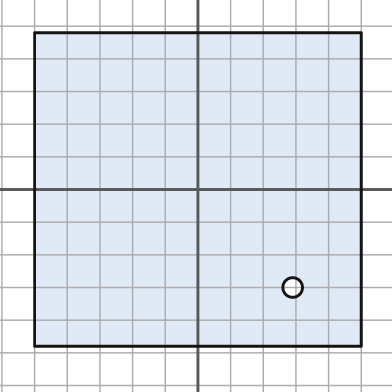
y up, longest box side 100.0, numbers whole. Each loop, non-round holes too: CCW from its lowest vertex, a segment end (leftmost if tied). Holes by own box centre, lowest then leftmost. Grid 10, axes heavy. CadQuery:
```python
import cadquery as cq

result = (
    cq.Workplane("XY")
    .moveTo(-50.0, -48.0)
    .lineTo(50.0, -48.0)
    .lineTo(50.0, 48.0)
    .lineTo(-50.0, 48.0)
    .close()
    .moveTo(29.0, -30.0)
    .circle(3.0)
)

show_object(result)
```